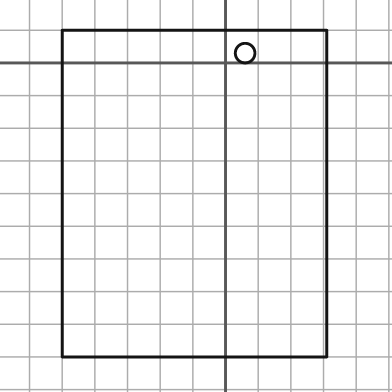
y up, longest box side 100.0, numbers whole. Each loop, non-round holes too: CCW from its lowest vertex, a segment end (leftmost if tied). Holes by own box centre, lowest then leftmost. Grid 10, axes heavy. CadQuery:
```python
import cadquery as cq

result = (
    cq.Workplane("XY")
    .moveTo(-50.0, -90.0)
    .lineTo(31.0, -90.0)
    .lineTo(31.0, 10.0)
    .lineTo(-50.0, 10.0)
    .close()
    .moveTo(6.0, 3.0)
    .circle(3.0)
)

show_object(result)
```